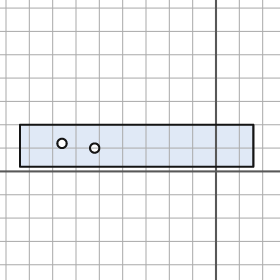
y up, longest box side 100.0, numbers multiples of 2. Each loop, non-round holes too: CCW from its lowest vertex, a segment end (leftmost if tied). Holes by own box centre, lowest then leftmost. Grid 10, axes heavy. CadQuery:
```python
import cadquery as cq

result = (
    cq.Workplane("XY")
    .moveTo(-84.0, 2.0)
    .lineTo(16.0, 2.0)
    .lineTo(16.0, 20.0)
    .lineTo(-84.0, 20.0)
    .close()
    .moveTo(-52.0, 10.0)
    .circle(2.0)
    .moveTo(-66.0, 12.0)
    .circle(2.0)
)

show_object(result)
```